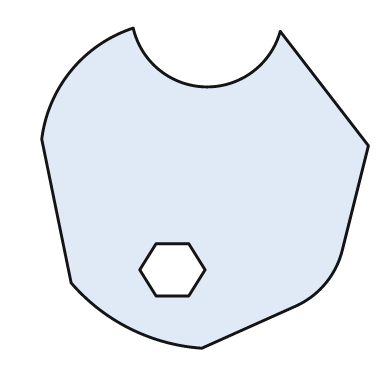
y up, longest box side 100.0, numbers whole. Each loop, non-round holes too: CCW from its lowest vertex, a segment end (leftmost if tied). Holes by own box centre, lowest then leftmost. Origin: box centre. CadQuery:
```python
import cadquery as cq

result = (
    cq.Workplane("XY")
    .moveTo(-1.0, -49.0)
    .lineTo(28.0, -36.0)
    .threePointArc((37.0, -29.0), (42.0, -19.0))
    .lineTo(50.0, 13.0)
    .lineTo(23.0, 48.0)
    .threePointArc((0.0, 31.0), (-22.0, 49.0))
    .threePointArc((-41.0, 36.0), (-50.0, 15.0))
    .lineTo(-41.0, -29.0)
    .threePointArc((-23.0, -43.0), (-1.0, -49.0))
    .close()
    .moveTo(-15.0, -33.0)
    .lineTo(-5.0, -33.0)
    .lineTo(0.0, -25.0)
    .lineTo(-5.0, -17.0)
    .lineTo(-15.0, -17.0)
    .lineTo(-20.0, -25.0)
    .close()
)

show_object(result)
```